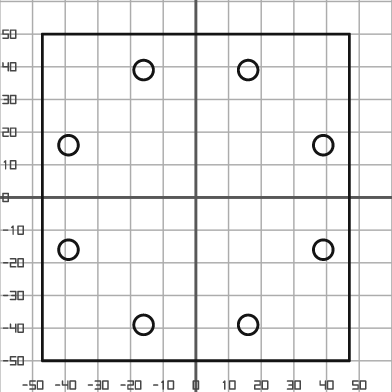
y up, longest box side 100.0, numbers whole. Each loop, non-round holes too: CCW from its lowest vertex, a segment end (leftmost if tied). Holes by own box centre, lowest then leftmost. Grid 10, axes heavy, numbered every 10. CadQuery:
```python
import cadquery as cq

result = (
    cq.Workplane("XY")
    .moveTo(-47.0, -50.0)
    .lineTo(47.0, -50.0)
    .lineTo(47.0, 50.0)
    .lineTo(-47.0, 50.0)
    .close()
    .moveTo(-16.0, -39.0)
    .circle(3.0)
    .moveTo(16.0, -39.0)
    .circle(3.0)
    .moveTo(-39.0, -16.0)
    .circle(3.0)
    .moveTo(39.0, -16.0)
    .circle(3.0)
    .moveTo(-39.0, 16.0)
    .circle(3.0)
    .moveTo(39.0, 16.0)
    .circle(3.0)
    .moveTo(-16.0, 39.0)
    .circle(3.0)
    .moveTo(16.0, 39.0)
    .circle(3.0)
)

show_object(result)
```